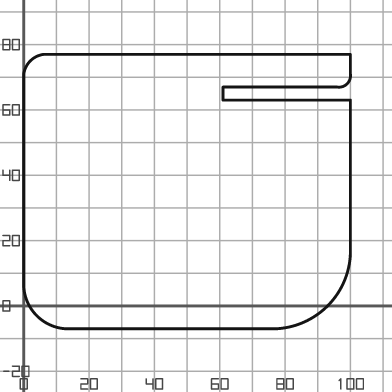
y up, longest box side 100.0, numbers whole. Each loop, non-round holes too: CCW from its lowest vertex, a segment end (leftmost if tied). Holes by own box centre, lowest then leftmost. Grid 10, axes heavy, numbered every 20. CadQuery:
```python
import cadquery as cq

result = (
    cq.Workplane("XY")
    .moveTo(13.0, -7.0)
    .lineTo(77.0, -7.0)
    .threePointArc((93.0, 0.0), (100.0, 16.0))
    .lineTo(100.0, 63.0)
    .lineTo(61.0, 63.0)
    .lineTo(61.0, 67.0)
    .lineTo(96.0, 67.0)
    .threePointArc((99.0, 68.0), (100.0, 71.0))
    .lineTo(100.0, 77.0)
    .lineTo(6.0, 77.0)
    .threePointArc((2.0, 75.0), (0.0, 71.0))
    .lineTo(0.0, 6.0)
    .threePointArc((4.0, -3.0), (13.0, -7.0))
    .close()
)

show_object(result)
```